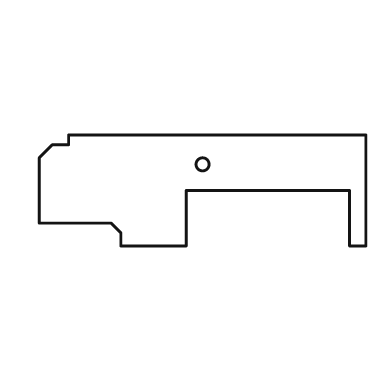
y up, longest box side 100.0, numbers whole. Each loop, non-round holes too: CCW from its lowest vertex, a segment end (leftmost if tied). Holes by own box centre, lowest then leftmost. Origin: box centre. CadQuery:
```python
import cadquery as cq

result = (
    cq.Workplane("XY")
    .moveTo(-25.0, -17.0)
    .lineTo(-5.0, -17.0)
    .lineTo(-5.0, 0.0)
    .lineTo(45.0, 0.0)
    .lineTo(45.0, -17.0)
    .lineTo(50.0, -17.0)
    .lineTo(50.0, 17.0)
    .lineTo(-41.0, 17.0)
    .lineTo(-41.0, 14.0)
    .lineTo(-46.0, 14.0)
    .lineTo(-50.0, 10.0)
    .lineTo(-50.0, -10.0)
    .lineTo(-28.0, -10.0)
    .lineTo(-25.0, -13.0)
    .close()
    .moveTo(0.0, 8.0)
    .circle(2.0)
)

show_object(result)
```